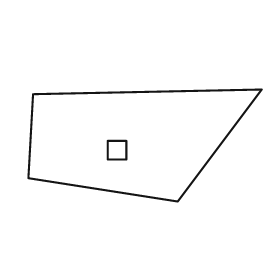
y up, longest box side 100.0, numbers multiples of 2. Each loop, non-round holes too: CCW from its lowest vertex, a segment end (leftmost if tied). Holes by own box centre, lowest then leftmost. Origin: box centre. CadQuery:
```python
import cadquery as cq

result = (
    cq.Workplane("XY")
    .moveTo(14.0, -24.0)
    .lineTo(50.0, 24.0)
    .lineTo(-48.0, 22.0)
    .lineTo(-50.0, -14.0)
    .close()
    .moveTo(-16.0, -6.0)
    .lineTo(-8.0, -6.0)
    .lineTo(-8.0, 2.0)
    .lineTo(-16.0, 2.0)
    .close()
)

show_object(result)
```